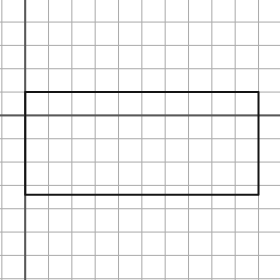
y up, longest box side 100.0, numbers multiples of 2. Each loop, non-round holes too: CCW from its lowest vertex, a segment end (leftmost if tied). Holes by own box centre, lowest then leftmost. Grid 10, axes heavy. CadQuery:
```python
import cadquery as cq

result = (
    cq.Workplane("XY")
    .moveTo(0.0, -34.0)
    .lineTo(100.0, -34.0)
    .lineTo(100.0, 10.0)
    .lineTo(0.0, 10.0)
    .close()
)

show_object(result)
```